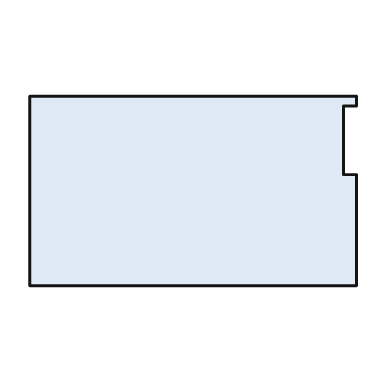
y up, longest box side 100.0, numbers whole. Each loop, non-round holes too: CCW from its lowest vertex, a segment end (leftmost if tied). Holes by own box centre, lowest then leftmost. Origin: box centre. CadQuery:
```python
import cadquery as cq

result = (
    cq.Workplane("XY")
    .moveTo(-50.0, -29.0)
    .lineTo(50.0, -29.0)
    .lineTo(50.0, 5.0)
    .lineTo(46.0, 5.0)
    .lineTo(46.0, 26.0)
    .lineTo(50.0, 26.0)
    .lineTo(50.0, 29.0)
    .lineTo(-50.0, 29.0)
    .close()
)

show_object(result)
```